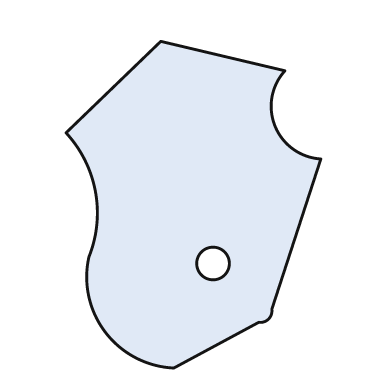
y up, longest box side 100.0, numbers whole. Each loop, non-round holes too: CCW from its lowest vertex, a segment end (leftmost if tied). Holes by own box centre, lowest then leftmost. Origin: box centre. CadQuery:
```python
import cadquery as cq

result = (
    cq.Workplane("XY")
    .moveTo(-6.0, -50.0)
    .lineTo(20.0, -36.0)
    .threePointArc((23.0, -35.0), (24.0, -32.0))
    .lineTo(39.0, 14.0)
    .threePointArc((25.0, 24.0), (28.0, 41.0))
    .lineTo(-10.0, 50.0)
    .lineTo(-39.0, 22.0)
    .threePointArc((-30.0, 4.0), (-32.0, -16.0))
    .threePointArc((-27.0, -39.0), (-6.0, -50.0))
    .close()
    .moveTo(6.0, -18.0)
    .circle(5.0)
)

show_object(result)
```